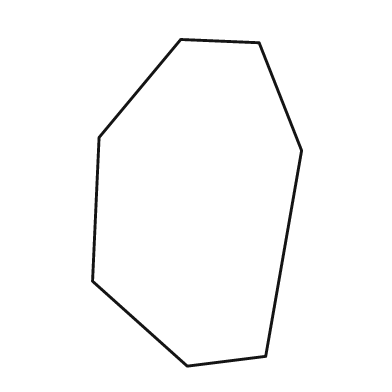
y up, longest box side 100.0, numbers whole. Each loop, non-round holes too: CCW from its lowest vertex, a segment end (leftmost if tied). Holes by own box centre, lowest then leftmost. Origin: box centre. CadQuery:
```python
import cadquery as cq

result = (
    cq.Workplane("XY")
    .moveTo(-3.0, -50.0)
    .lineTo(21.0, -47.0)
    .lineTo(32.0, 16.0)
    .lineTo(19.0, 49.0)
    .lineTo(-5.0, 50.0)
    .lineTo(-30.0, 20.0)
    .lineTo(-32.0, -24.0)
    .close()
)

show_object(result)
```